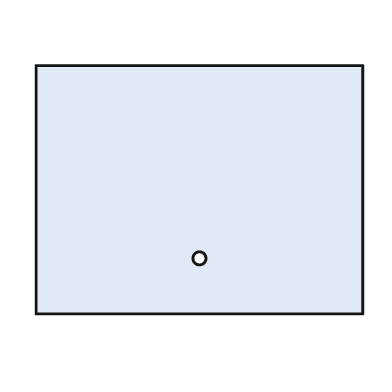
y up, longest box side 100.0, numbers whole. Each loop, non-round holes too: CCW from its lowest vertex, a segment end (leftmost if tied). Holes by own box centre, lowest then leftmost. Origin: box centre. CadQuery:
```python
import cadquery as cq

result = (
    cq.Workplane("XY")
    .moveTo(-50.0, -38.0)
    .lineTo(50.0, -38.0)
    .lineTo(50.0, 38.0)
    .lineTo(-50.0, 38.0)
    .close()
    .moveTo(0.0, -21.0)
    .circle(2.0)
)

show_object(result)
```